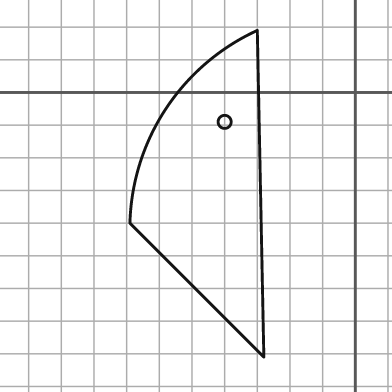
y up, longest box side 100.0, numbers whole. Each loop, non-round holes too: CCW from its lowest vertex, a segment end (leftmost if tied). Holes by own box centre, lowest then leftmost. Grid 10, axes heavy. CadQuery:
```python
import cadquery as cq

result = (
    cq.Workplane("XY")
    .moveTo(-28.0, -81.0)
    .lineTo(-30.0, 19.0)
    .threePointArc((-58.0, -5.0), (-69.0, -40.0))
    .close()
    .moveTo(-40.0, -9.0)
    .circle(2.0)
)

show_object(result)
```